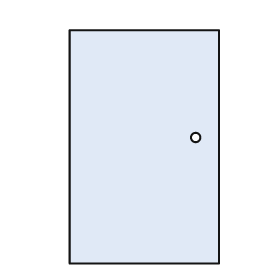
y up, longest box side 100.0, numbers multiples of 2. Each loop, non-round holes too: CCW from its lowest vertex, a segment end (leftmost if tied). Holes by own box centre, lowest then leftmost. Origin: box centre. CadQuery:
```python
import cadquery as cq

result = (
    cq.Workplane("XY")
    .moveTo(-32.0, -50.0)
    .lineTo(32.0, -50.0)
    .lineTo(32.0, 50.0)
    .lineTo(-32.0, 50.0)
    .close()
    .moveTo(22.0, 4.0)
    .circle(2.0)
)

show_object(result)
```